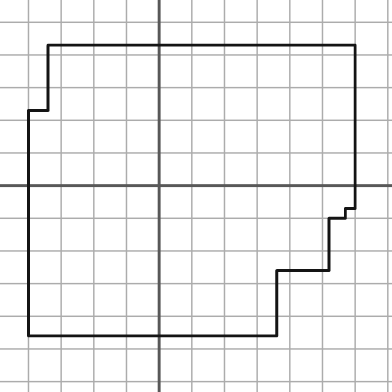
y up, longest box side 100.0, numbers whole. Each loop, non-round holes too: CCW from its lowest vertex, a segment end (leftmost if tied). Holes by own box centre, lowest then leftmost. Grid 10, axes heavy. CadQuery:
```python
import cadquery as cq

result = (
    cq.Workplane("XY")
    .moveTo(-40.0, -46.0)
    .lineTo(36.0, -46.0)
    .lineTo(36.0, -26.0)
    .lineTo(52.0, -26.0)
    .lineTo(52.0, -10.0)
    .lineTo(57.0, -10.0)
    .lineTo(57.0, -7.0)
    .lineTo(60.0, -7.0)
    .lineTo(60.0, 43.0)
    .lineTo(-34.0, 43.0)
    .lineTo(-34.0, 23.0)
    .lineTo(-40.0, 23.0)
    .close()
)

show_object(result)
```